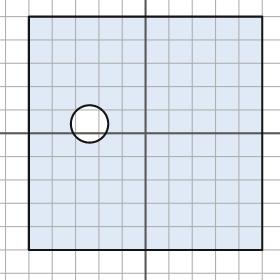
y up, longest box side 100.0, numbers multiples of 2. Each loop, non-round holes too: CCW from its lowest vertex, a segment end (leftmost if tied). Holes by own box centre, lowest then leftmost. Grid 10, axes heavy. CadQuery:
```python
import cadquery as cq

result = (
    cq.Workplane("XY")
    .moveTo(-50.0, -50.0)
    .lineTo(50.0, -50.0)
    .lineTo(50.0, 50.0)
    .lineTo(-50.0, 50.0)
    .close()
    .moveTo(-24.0, 4.0)
    .circle(8.0)
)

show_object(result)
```